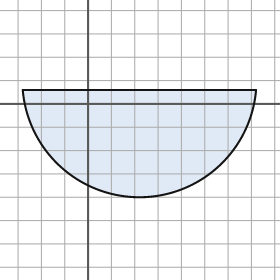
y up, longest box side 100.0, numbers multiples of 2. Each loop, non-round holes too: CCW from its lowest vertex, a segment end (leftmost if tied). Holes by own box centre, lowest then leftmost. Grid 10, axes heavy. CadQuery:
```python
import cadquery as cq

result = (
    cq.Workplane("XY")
    .moveTo(-28.0, 6.0)
    .threePointArc((22.0, -40.0), (72.0, 6.0))
    .close()
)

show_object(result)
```